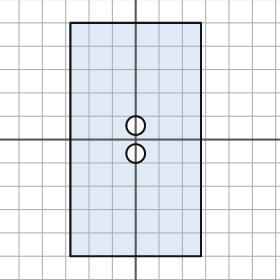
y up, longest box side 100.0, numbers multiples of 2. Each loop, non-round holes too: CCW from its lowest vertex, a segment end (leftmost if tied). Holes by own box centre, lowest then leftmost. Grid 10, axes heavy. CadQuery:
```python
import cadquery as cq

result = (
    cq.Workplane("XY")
    .moveTo(-28.0, -50.0)
    .lineTo(28.0, -50.0)
    .lineTo(28.0, 50.0)
    .lineTo(-28.0, 50.0)
    .close()
    .moveTo(0.0, -6.0)
    .circle(4.0)
    .moveTo(0.0, 6.0)
    .circle(4.0)
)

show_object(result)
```